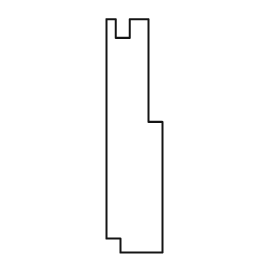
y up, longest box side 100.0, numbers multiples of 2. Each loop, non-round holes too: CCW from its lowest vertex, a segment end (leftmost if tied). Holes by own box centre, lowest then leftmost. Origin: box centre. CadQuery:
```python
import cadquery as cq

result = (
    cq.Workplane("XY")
    .moveTo(-6.0, -50.0)
    .lineTo(12.0, -50.0)
    .lineTo(12.0, 6.0)
    .lineTo(6.0, 6.0)
    .lineTo(6.0, 50.0)
    .lineTo(-2.0, 50.0)
    .lineTo(-2.0, 42.0)
    .lineTo(-8.0, 42.0)
    .lineTo(-8.0, 50.0)
    .lineTo(-12.0, 50.0)
    .lineTo(-12.0, -44.0)
    .lineTo(-6.0, -44.0)
    .close()
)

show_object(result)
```